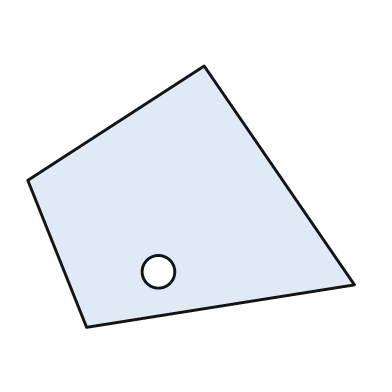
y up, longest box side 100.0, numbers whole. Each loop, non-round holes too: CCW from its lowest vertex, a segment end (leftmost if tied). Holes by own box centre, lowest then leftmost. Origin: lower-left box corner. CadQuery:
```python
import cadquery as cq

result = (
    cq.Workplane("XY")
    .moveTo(18.0, 0.0)
    .lineTo(100.0, 13.0)
    .lineTo(54.0, 80.0)
    .lineTo(0.0, 45.0)
    .close()
    .moveTo(40.0, 17.0)
    .circle(5.0)
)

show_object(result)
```